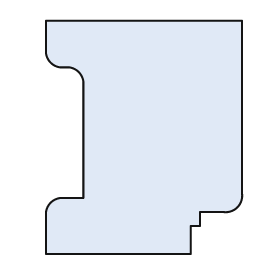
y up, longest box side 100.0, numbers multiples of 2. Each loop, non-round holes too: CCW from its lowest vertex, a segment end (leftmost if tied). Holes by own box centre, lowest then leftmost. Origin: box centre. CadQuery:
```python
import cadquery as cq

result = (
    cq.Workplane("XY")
    .moveTo(-42.0, -50.0)
    .lineTo(20.0, -50.0)
    .lineTo(20.0, -38.0)
    .lineTo(24.0, -38.0)
    .lineTo(24.0, -32.0)
    .lineTo(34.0, -32.0)
    .threePointArc((40.0, -30.0), (42.0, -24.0))
    .lineTo(42.0, 50.0)
    .lineTo(-42.0, 50.0)
    .lineTo(-42.0, 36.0)
    .threePointArc((-40.0, 32.0), (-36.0, 30.0))
    .lineTo(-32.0, 30.0)
    .threePointArc((-28.0, 28.0), (-26.0, 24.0))
    .lineTo(-26.0, -26.0)
    .lineTo(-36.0, -26.0)
    .threePointArc((-40.0, -28.0), (-42.0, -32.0))
    .close()
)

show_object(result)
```